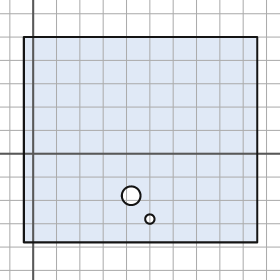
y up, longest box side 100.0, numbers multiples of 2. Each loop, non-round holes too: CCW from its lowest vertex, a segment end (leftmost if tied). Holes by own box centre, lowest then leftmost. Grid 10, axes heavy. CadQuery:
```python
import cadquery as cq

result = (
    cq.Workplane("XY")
    .moveTo(-4.0, -38.0)
    .lineTo(96.0, -38.0)
    .lineTo(96.0, 50.0)
    .lineTo(-4.0, 50.0)
    .close()
    .moveTo(50.0, -28.0)
    .circle(2.0)
    .moveTo(42.0, -18.0)
    .circle(4.0)
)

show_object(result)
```